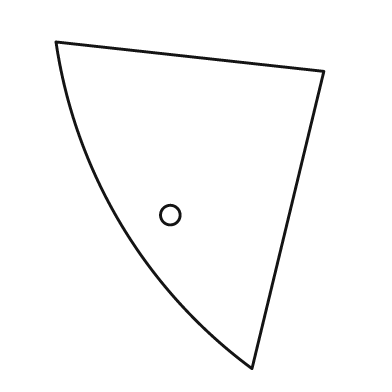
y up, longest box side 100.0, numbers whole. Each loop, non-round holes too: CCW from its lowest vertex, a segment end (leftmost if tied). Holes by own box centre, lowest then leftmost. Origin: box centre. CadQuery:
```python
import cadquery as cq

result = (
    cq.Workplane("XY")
    .moveTo(19.0, -50.0)
    .lineTo(41.0, 41.0)
    .lineTo(-41.0, 50.0)
    .threePointArc((-21.0, -6.0), (19.0, -50.0))
    .close()
    .moveTo(-6.0, -3.0)
    .circle(3.0)
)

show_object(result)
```